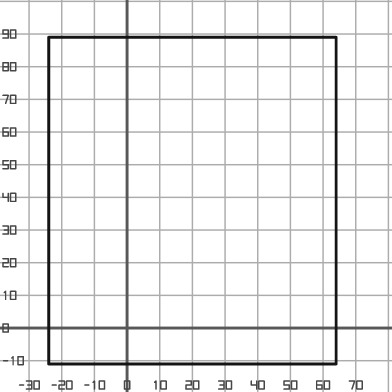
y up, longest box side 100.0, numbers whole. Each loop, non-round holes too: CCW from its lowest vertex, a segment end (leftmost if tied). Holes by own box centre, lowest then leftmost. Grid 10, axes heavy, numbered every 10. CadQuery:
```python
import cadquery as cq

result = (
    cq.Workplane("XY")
    .moveTo(-24.0, -11.0)
    .lineTo(64.0, -11.0)
    .lineTo(64.0, 89.0)
    .lineTo(-24.0, 89.0)
    .close()
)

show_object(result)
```